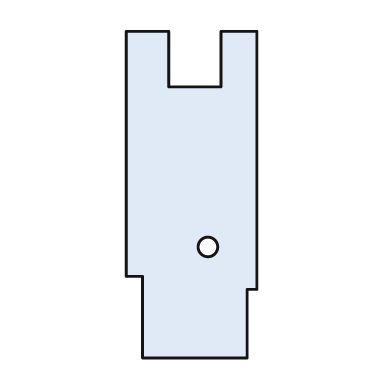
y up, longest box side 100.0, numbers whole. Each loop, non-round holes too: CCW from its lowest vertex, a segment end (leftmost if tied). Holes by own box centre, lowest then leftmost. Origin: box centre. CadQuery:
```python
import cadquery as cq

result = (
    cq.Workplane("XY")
    .moveTo(-15.0, -50.0)
    .lineTo(17.0, -50.0)
    .lineTo(17.0, -29.0)
    .lineTo(20.0, -29.0)
    .lineTo(20.0, 50.0)
    .lineTo(9.0, 50.0)
    .lineTo(9.0, 33.0)
    .lineTo(-7.0, 33.0)
    .lineTo(-7.0, 50.0)
    .lineTo(-20.0, 50.0)
    .lineTo(-20.0, -25.0)
    .lineTo(-15.0, -25.0)
    .close()
    .moveTo(5.0, -16.0)
    .circle(3.0)
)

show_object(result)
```